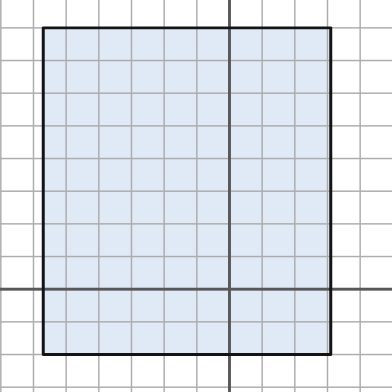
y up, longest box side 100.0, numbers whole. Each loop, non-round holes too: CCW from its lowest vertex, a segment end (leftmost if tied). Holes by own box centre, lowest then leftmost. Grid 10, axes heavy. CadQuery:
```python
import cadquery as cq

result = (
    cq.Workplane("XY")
    .moveTo(-57.0, -20.0)
    .lineTo(31.0, -20.0)
    .lineTo(31.0, 80.0)
    .lineTo(-57.0, 80.0)
    .close()
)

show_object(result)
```